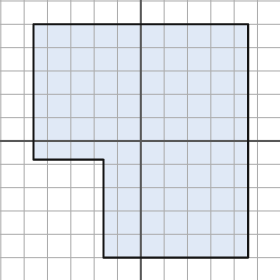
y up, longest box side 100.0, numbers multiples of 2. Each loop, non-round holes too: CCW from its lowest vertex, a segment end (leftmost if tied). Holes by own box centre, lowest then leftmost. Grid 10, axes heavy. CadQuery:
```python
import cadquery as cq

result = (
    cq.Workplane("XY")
    .moveTo(-16.0, -50.0)
    .lineTo(46.0, -50.0)
    .lineTo(46.0, 50.0)
    .lineTo(-46.0, 50.0)
    .lineTo(-46.0, -8.0)
    .lineTo(-16.0, -8.0)
    .close()
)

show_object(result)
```